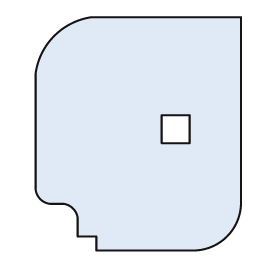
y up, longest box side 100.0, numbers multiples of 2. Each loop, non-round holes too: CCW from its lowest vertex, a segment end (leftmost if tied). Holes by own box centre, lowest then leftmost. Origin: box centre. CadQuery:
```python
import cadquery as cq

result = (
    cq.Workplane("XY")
    .moveTo(-18.0, -50.0)
    .lineTo(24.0, -50.0)
    .threePointArc((38.0, -44.0), (44.0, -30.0))
    .lineTo(44.0, 50.0)
    .lineTo(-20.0, 50.0)
    .threePointArc((-36.0, 42.0), (-44.0, 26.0))
    .lineTo(-44.0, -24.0)
    .threePointArc((-42.0, -28.0), (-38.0, -30.0))
    .lineTo(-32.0, -30.0)
    .threePointArc((-28.0, -32.0), (-26.0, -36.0))
    .lineTo(-26.0, -44.0)
    .lineTo(-18.0, -44.0)
    .close()
    .moveTo(10.0, -4.0)
    .lineTo(22.0, -4.0)
    .lineTo(22.0, 8.0)
    .lineTo(10.0, 8.0)
    .close()
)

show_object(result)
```